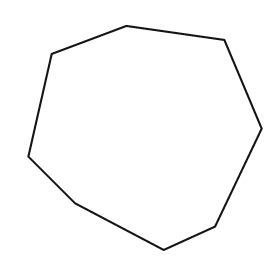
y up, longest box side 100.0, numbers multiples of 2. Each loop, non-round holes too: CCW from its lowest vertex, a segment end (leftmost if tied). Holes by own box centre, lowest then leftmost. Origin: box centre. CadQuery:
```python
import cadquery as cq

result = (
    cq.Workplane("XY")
    .moveTo(8.0, -48.0)
    .lineTo(30.0, -38.0)
    .lineTo(50.0, 4.0)
    .lineTo(34.0, 42.0)
    .lineTo(-8.0, 48.0)
    .lineTo(-40.0, 36.0)
    .lineTo(-50.0, -8.0)
    .lineTo(-30.0, -28.0)
    .close()
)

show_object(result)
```